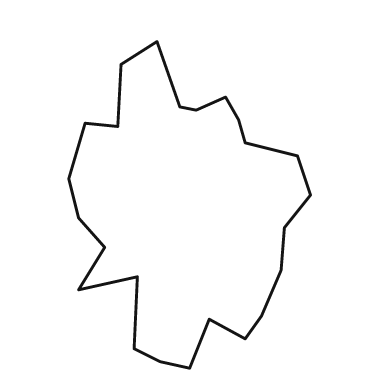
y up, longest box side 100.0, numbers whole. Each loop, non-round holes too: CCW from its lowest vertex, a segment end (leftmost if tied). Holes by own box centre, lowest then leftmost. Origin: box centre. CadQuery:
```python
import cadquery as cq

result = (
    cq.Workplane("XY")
    .moveTo(0.0, -50.0)
    .lineTo(6.0, -35.0)
    .lineTo(17.0, -41.0)
    .lineTo(22.0, -34.0)
    .lineTo(28.0, -20.0)
    .lineTo(29.0, -7.0)
    .lineTo(37.0, 3.0)
    .lineTo(33.0, 15.0)
    .lineTo(17.0, 19.0)
    .lineTo(15.0, 26.0)
    .lineTo(11.0, 33.0)
    .lineTo(2.0, 29.0)
    .lineTo(-3.0, 30.0)
    .lineTo(-10.0, 50.0)
    .lineTo(-21.0, 43.0)
    .lineTo(-22.0, 24.0)
    .lineTo(-32.0, 25.0)
    .lineTo(-37.0, 8.0)
    .lineTo(-34.0, -4.0)
    .lineTo(-26.0, -13.0)
    .lineTo(-34.0, -26.0)
    .lineTo(-16.0, -22.0)
    .lineTo(-17.0, -44.0)
    .lineTo(-9.0, -48.0)
    .close()
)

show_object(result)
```